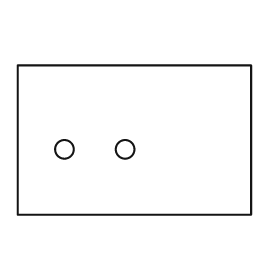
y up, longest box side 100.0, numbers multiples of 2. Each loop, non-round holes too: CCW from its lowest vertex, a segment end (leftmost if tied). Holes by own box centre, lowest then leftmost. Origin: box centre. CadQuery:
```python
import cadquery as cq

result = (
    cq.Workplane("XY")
    .moveTo(-50.0, -32.0)
    .lineTo(50.0, -32.0)
    .lineTo(50.0, 32.0)
    .lineTo(-50.0, 32.0)
    .close()
    .moveTo(-30.0, -4.0)
    .circle(4.0)
    .moveTo(-4.0, -4.0)
    .circle(4.0)
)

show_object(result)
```